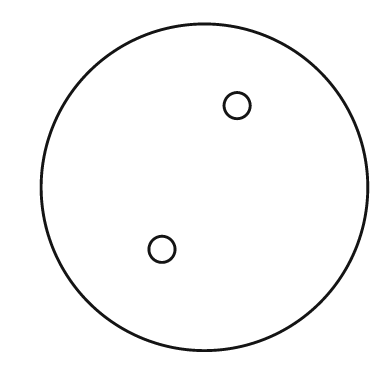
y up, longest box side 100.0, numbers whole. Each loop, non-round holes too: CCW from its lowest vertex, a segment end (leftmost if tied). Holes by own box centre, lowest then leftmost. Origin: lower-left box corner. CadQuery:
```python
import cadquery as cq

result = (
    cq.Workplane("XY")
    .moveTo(50.0, 50.0)
    .circle(50.0)
    .moveTo(37.0, 31.0)
    .circle(4.0)
    .moveTo(60.0, 75.0)
    .circle(4.0)
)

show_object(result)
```